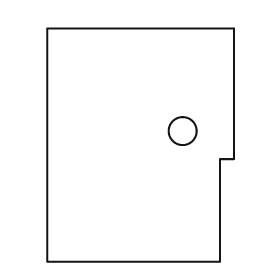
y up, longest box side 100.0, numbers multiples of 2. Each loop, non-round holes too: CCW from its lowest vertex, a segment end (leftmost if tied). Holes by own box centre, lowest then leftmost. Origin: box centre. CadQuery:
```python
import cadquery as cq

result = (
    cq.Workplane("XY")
    .moveTo(-40.0, -50.0)
    .lineTo(34.0, -50.0)
    .lineTo(34.0, -6.0)
    .lineTo(40.0, -6.0)
    .lineTo(40.0, 50.0)
    .lineTo(-40.0, 50.0)
    .close()
    .moveTo(18.0, 6.0)
    .circle(6.0)
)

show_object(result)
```